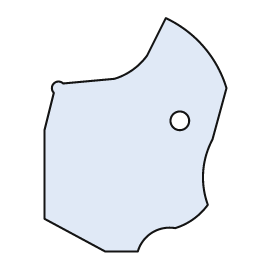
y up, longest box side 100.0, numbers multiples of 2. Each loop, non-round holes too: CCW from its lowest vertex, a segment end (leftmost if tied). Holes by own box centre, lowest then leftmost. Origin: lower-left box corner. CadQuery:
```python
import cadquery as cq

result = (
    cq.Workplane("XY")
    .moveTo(26.0, 0.0)
    .lineTo(40.0, 0.0)
    .threePointArc((46.0, 8.0), (56.0, 10.0))
    .threePointArc((64.0, 14.0), (70.0, 20.0))
    .threePointArc((68.0, 34.0), (72.0, 48.0))
    .lineTo(78.0, 70.0)
    .threePointArc((68.0, 88.0), (52.0, 100.0))
    .lineTo(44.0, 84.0)
    .threePointArc((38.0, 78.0), (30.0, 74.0))
    .lineTo(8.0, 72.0)
    .threePointArc((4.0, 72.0), (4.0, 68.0))
    .lineTo(0.0, 52.0)
    .lineTo(0.0, 14.0)
    .close()
    .moveTo(58.0, 56.0)
    .circle(4.0)
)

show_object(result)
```